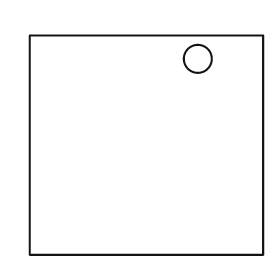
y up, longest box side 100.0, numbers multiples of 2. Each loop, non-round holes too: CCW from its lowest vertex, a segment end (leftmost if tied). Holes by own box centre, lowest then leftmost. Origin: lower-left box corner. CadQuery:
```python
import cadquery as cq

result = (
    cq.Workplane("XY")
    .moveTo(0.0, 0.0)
    .lineTo(100.0, 0.0)
    .lineTo(100.0, 94.0)
    .lineTo(0.0, 94.0)
    .close()
    .moveTo(72.0, 84.0)
    .circle(6.0)
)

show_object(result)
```